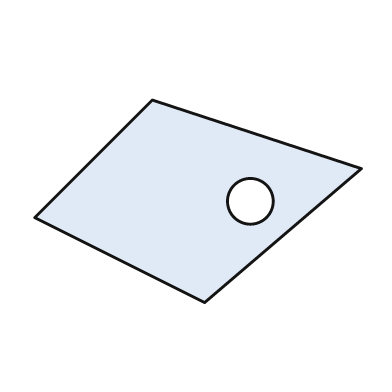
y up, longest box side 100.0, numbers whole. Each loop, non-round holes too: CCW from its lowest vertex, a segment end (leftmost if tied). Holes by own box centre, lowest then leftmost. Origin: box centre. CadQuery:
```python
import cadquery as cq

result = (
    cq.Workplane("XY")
    .moveTo(2.0, -31.0)
    .lineTo(50.0, 10.0)
    .lineTo(-14.0, 31.0)
    .lineTo(-50.0, -5.0)
    .close()
    .moveTo(16.0, 0.0)
    .circle(7.0)
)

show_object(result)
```